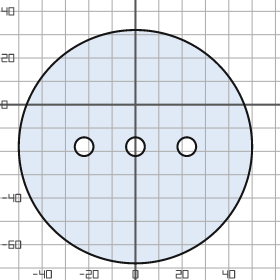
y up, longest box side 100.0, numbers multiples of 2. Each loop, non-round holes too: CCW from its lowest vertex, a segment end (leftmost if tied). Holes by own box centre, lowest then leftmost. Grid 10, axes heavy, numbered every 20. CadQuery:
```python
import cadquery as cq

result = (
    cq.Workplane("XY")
    .moveTo(0.0, -18.0)
    .circle(50.0)
    .moveTo(-22.0, -18.0)
    .circle(4.0)
    .moveTo(0.0, -18.0)
    .circle(4.0)
    .moveTo(22.0, -18.0)
    .circle(4.0)
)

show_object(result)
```